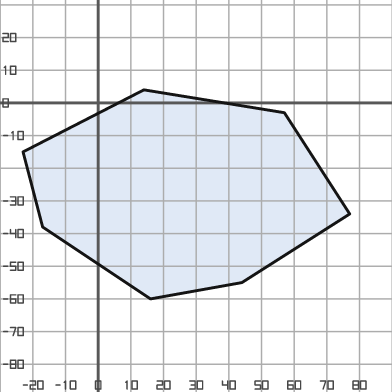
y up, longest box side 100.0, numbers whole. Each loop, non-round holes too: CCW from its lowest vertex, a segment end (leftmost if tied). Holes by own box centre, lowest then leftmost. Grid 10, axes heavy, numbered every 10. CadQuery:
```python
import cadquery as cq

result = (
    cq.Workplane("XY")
    .moveTo(16.0, -60.0)
    .lineTo(44.0, -55.0)
    .lineTo(77.0, -34.0)
    .lineTo(57.0, -3.0)
    .lineTo(14.0, 4.0)
    .lineTo(-23.0, -15.0)
    .lineTo(-17.0, -38.0)
    .close()
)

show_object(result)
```